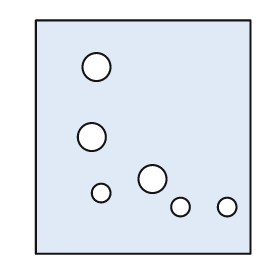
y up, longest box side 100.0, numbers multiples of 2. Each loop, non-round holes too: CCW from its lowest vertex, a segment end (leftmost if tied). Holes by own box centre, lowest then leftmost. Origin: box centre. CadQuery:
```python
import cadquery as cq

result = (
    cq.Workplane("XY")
    .moveTo(-46.0, -50.0)
    .lineTo(46.0, -50.0)
    .lineTo(46.0, 50.0)
    .lineTo(-46.0, 50.0)
    .close()
    .moveTo(16.0, -30.0)
    .circle(4.0)
    .moveTo(36.0, -30.0)
    .circle(4.0)
    .moveTo(-18.0, -24.0)
    .circle(4.0)
    .moveTo(4.0, -18.0)
    .circle(6.0)
    .moveTo(-22.0, 0.0)
    .circle(6.0)
    .moveTo(-20.0, 30.0)
    .circle(6.0)
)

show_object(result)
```